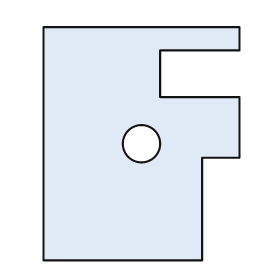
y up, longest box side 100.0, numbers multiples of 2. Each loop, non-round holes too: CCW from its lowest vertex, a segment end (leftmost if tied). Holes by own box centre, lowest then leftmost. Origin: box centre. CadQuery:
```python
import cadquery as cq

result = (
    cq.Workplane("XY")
    .moveTo(-42.0, -50.0)
    .lineTo(26.0, -50.0)
    .lineTo(26.0, -6.0)
    .lineTo(42.0, -6.0)
    .lineTo(42.0, 20.0)
    .lineTo(8.0, 20.0)
    .lineTo(8.0, 40.0)
    .lineTo(42.0, 40.0)
    .lineTo(42.0, 50.0)
    .lineTo(-42.0, 50.0)
    .close()
    .moveTo(0.0, 0.0)
    .circle(8.0)
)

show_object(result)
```